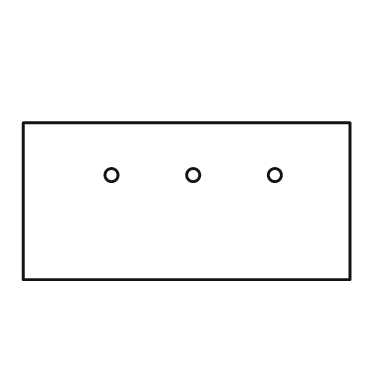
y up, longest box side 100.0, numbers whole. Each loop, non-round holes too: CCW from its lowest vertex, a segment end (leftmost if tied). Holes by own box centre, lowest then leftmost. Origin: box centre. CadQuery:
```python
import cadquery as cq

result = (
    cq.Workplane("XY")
    .moveTo(-50.0, -24.0)
    .lineTo(50.0, -24.0)
    .lineTo(50.0, 24.0)
    .lineTo(-50.0, 24.0)
    .close()
    .moveTo(-23.0, 8.0)
    .circle(2.0)
    .moveTo(2.0, 8.0)
    .circle(2.0)
    .moveTo(27.0, 8.0)
    .circle(2.0)
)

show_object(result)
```